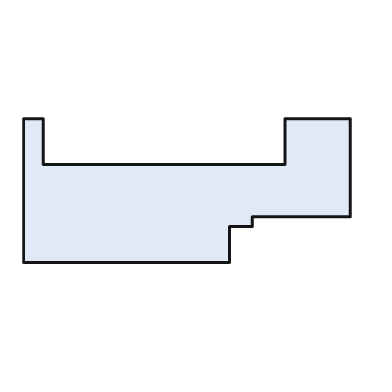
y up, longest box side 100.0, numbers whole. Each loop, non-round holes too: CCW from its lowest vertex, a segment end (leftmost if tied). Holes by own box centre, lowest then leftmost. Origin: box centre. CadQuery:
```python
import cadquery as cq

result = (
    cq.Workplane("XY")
    .moveTo(-50.0, -22.0)
    .lineTo(13.0, -22.0)
    .lineTo(13.0, -11.0)
    .lineTo(20.0, -11.0)
    .lineTo(20.0, -8.0)
    .lineTo(50.0, -8.0)
    .lineTo(50.0, 22.0)
    .lineTo(30.0, 22.0)
    .lineTo(30.0, 8.0)
    .lineTo(-44.0, 8.0)
    .lineTo(-44.0, 22.0)
    .lineTo(-50.0, 22.0)
    .close()
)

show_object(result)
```